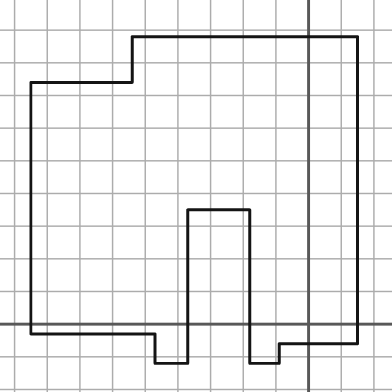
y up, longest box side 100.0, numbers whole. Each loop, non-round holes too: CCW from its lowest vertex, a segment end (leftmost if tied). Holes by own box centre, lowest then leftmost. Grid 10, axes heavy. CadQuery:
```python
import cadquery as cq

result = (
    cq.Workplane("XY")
    .moveTo(-47.0, -12.0)
    .lineTo(-37.0, -12.0)
    .lineTo(-37.0, 35.0)
    .lineTo(-18.0, 35.0)
    .lineTo(-18.0, -12.0)
    .lineTo(-9.0, -12.0)
    .lineTo(-9.0, -6.0)
    .lineTo(15.0, -6.0)
    .lineTo(15.0, 88.0)
    .lineTo(-54.0, 88.0)
    .lineTo(-54.0, 74.0)
    .lineTo(-85.0, 74.0)
    .lineTo(-85.0, -3.0)
    .lineTo(-47.0, -3.0)
    .close()
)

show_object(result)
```